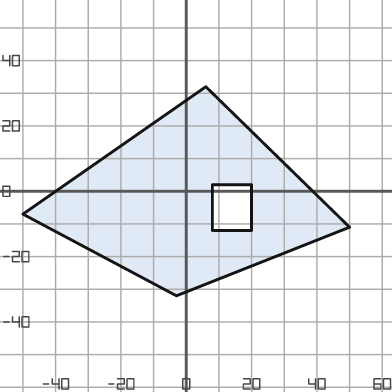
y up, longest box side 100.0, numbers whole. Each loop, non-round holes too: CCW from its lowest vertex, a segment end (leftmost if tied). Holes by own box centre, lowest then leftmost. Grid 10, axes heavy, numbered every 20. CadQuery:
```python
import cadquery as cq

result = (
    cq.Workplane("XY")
    .moveTo(-3.0, -32.0)
    .lineTo(50.0, -11.0)
    .lineTo(6.0, 32.0)
    .lineTo(-50.0, -7.0)
    .close()
    .moveTo(8.0, -12.0)
    .lineTo(20.0, -12.0)
    .lineTo(20.0, 2.0)
    .lineTo(8.0, 2.0)
    .close()
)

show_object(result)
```